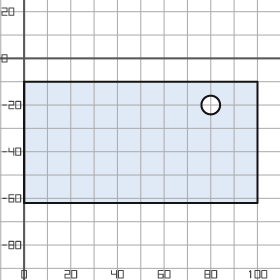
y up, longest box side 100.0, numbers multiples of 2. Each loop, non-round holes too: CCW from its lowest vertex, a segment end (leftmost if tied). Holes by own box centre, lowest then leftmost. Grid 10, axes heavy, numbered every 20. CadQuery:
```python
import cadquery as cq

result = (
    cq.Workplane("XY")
    .moveTo(0.0, -62.0)
    .lineTo(100.0, -62.0)
    .lineTo(100.0, -10.0)
    .lineTo(0.0, -10.0)
    .close()
    .moveTo(80.0, -20.0)
    .circle(4.0)
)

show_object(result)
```